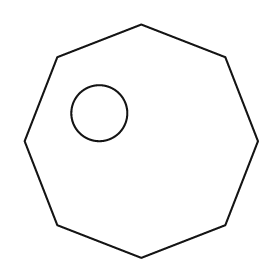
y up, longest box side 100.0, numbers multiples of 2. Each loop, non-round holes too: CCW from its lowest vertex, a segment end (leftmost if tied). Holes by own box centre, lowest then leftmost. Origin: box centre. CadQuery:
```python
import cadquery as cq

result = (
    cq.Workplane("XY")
    .moveTo(0.0, -50.0)
    .lineTo(36.0, -36.0)
    .lineTo(50.0, 0.0)
    .lineTo(36.0, 36.0)
    .lineTo(0.0, 50.0)
    .lineTo(-36.0, 36.0)
    .lineTo(-50.0, 0.0)
    .lineTo(-36.0, -36.0)
    .close()
    .moveTo(-18.0, 12.0)
    .circle(12.0)
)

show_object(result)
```